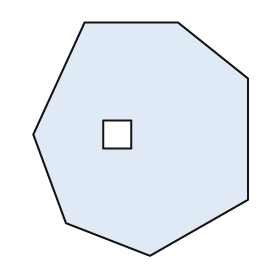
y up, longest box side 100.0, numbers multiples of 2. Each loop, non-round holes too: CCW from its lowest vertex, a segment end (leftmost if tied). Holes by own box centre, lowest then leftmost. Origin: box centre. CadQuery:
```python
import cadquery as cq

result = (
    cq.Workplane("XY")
    .moveTo(4.0, -50.0)
    .lineTo(46.0, -26.0)
    .lineTo(46.0, 26.0)
    .lineTo(16.0, 50.0)
    .lineTo(-24.0, 50.0)
    .lineTo(-46.0, 2.0)
    .lineTo(-32.0, -36.0)
    .close()
    .moveTo(-16.0, -4.0)
    .lineTo(-4.0, -4.0)
    .lineTo(-4.0, 8.0)
    .lineTo(-16.0, 8.0)
    .close()
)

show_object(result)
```